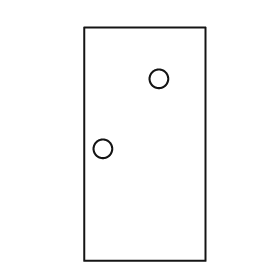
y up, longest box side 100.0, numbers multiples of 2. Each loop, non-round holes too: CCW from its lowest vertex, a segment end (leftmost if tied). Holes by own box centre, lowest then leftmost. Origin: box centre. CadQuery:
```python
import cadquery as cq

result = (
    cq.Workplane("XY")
    .moveTo(-26.0, -50.0)
    .lineTo(26.0, -50.0)
    .lineTo(26.0, 50.0)
    .lineTo(-26.0, 50.0)
    .close()
    .moveTo(-18.0, -2.0)
    .circle(4.0)
    .moveTo(6.0, 28.0)
    .circle(4.0)
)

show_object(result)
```